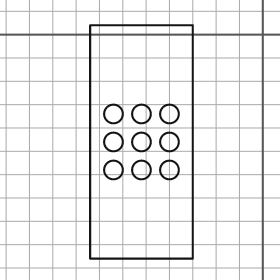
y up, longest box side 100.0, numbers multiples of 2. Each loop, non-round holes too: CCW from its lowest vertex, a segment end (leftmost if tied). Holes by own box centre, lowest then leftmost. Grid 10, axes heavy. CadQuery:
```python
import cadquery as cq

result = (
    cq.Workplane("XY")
    .moveTo(-74.0, -96.0)
    .lineTo(-30.0, -96.0)
    .lineTo(-30.0, 4.0)
    .lineTo(-74.0, 4.0)
    .close()
    .moveTo(-64.0, -58.0)
    .circle(4.0)
    .moveTo(-52.0, -58.0)
    .circle(4.0)
    .moveTo(-40.0, -58.0)
    .circle(4.0)
    .moveTo(-64.0, -46.0)
    .circle(4.0)
    .moveTo(-52.0, -46.0)
    .circle(4.0)
    .moveTo(-40.0, -46.0)
    .circle(4.0)
    .moveTo(-64.0, -34.0)
    .circle(4.0)
    .moveTo(-52.0, -34.0)
    .circle(4.0)
    .moveTo(-40.0, -34.0)
    .circle(4.0)
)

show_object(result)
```